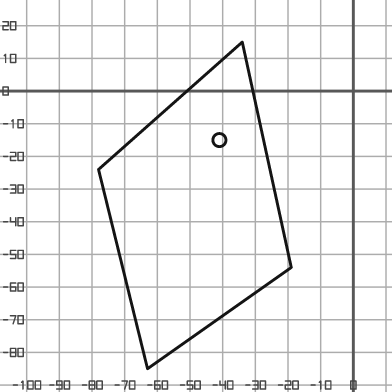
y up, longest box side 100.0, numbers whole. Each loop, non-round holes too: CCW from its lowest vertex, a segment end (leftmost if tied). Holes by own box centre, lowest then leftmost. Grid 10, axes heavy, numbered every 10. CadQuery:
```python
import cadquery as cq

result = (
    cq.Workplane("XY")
    .moveTo(-63.0, -85.0)
    .lineTo(-19.0, -54.0)
    .lineTo(-34.0, 15.0)
    .lineTo(-78.0, -24.0)
    .close()
    .moveTo(-41.0, -15.0)
    .circle(2.0)
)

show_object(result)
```